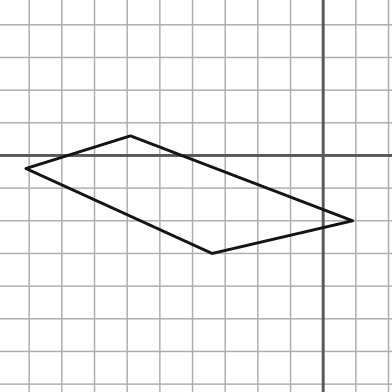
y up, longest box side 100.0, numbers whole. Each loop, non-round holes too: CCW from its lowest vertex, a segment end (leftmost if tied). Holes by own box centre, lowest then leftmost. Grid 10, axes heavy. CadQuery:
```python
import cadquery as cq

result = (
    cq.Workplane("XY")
    .moveTo(-34.0, -30.0)
    .lineTo(9.0, -20.0)
    .lineTo(-59.0, 6.0)
    .lineTo(-91.0, -4.0)
    .close()
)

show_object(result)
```